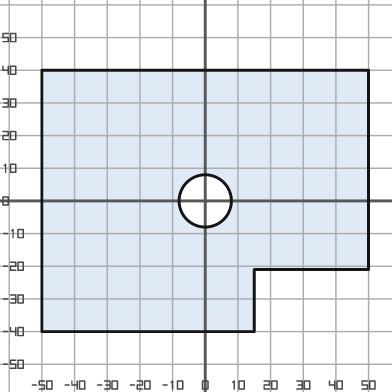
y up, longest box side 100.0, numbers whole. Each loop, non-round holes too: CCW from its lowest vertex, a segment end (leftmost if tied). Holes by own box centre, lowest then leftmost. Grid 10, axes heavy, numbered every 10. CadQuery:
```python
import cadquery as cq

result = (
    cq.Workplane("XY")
    .moveTo(-50.0, -40.0)
    .lineTo(15.0, -40.0)
    .lineTo(15.0, -21.0)
    .lineTo(50.0, -21.0)
    .lineTo(50.0, 40.0)
    .lineTo(-50.0, 40.0)
    .close()
    .moveTo(0.0, 0.0)
    .circle(8.0)
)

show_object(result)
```